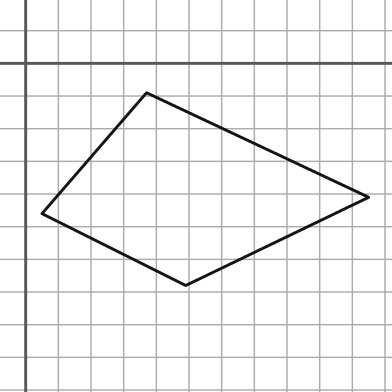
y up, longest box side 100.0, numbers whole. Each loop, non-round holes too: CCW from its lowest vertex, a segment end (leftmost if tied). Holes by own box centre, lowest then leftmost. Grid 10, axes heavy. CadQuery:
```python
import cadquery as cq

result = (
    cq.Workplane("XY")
    .moveTo(49.0, -68.0)
    .lineTo(105.0, -41.0)
    .lineTo(37.0, -9.0)
    .lineTo(5.0, -46.0)
    .close()
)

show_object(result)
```